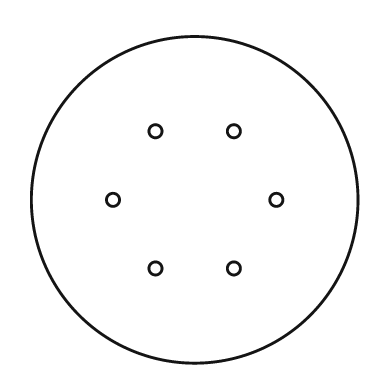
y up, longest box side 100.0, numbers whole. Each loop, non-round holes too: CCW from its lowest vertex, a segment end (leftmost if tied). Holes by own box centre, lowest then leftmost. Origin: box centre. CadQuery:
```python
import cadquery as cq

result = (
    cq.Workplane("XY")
    .moveTo(0.0, 0.0)
    .circle(50.0)
    .moveTo(-12.0, -21.0)
    .circle(2.0)
    .moveTo(12.0, -21.0)
    .circle(2.0)
    .moveTo(-25.0, 0.0)
    .circle(2.0)
    .moveTo(25.0, 0.0)
    .circle(2.0)
    .moveTo(-12.0, 21.0)
    .circle(2.0)
    .moveTo(12.0, 21.0)
    .circle(2.0)
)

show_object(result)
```